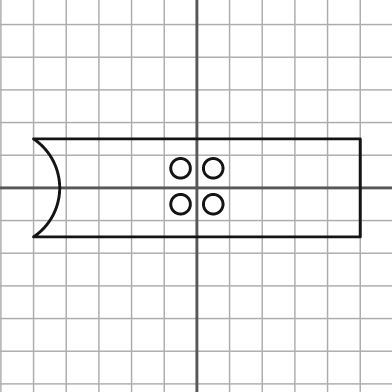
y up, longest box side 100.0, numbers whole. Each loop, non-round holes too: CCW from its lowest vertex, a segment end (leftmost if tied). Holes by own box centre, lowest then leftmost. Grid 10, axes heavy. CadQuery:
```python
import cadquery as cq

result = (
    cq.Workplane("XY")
    .moveTo(-50.0, -15.0)
    .lineTo(50.0, -15.0)
    .lineTo(50.0, 15.0)
    .lineTo(-50.0, 15.0)
    .threePointArc((-42.0, 0.0), (-50.0, -15.0))
    .close()
    .moveTo(-5.0, -5.0)
    .circle(3.0)
    .moveTo(5.0, -5.0)
    .circle(3.0)
    .moveTo(-5.0, 6.0)
    .circle(3.0)
    .moveTo(5.0, 6.0)
    .circle(3.0)
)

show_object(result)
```